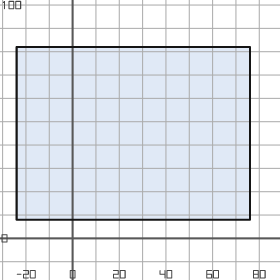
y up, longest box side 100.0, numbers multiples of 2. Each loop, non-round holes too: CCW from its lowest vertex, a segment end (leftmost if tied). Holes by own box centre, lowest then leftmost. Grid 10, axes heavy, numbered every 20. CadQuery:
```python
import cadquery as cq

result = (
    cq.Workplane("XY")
    .moveTo(-24.0, 8.0)
    .lineTo(76.0, 8.0)
    .lineTo(76.0, 82.0)
    .lineTo(-24.0, 82.0)
    .close()
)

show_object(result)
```